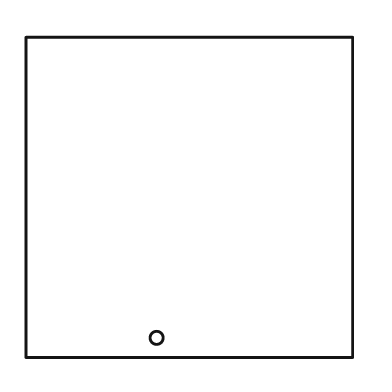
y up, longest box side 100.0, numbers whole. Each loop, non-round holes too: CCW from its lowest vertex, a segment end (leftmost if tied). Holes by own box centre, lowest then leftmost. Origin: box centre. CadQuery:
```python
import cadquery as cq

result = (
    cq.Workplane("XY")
    .moveTo(-50.0, -49.0)
    .lineTo(50.0, -49.0)
    .lineTo(50.0, 49.0)
    .lineTo(-50.0, 49.0)
    .close()
    .moveTo(-10.0, -43.0)
    .circle(2.0)
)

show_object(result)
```